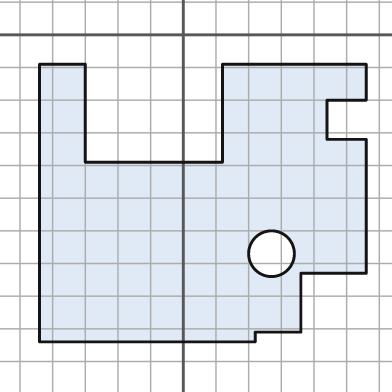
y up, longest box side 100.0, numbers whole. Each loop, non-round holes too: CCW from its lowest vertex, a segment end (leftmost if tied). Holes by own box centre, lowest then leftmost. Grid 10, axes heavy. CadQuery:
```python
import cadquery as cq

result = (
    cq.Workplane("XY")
    .moveTo(-44.0, -94.0)
    .lineTo(22.0, -94.0)
    .lineTo(22.0, -91.0)
    .lineTo(36.0, -91.0)
    .lineTo(36.0, -73.0)
    .lineTo(56.0, -73.0)
    .lineTo(56.0, -32.0)
    .lineTo(44.0, -32.0)
    .lineTo(44.0, -20.0)
    .lineTo(56.0, -20.0)
    .lineTo(56.0, -9.0)
    .lineTo(12.0, -9.0)
    .lineTo(12.0, -39.0)
    .lineTo(-30.0, -39.0)
    .lineTo(-30.0, -9.0)
    .lineTo(-44.0, -9.0)
    .close()
    .moveTo(27.0, -67.0)
    .circle(7.0)
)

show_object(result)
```